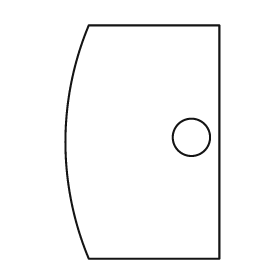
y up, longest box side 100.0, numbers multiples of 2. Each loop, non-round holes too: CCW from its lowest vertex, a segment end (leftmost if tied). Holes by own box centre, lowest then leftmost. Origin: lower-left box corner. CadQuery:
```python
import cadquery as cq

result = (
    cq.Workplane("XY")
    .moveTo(10.0, 0.0)
    .lineTo(66.0, 0.0)
    .lineTo(66.0, 100.0)
    .lineTo(10.0, 100.0)
    .threePointArc((0.0, 50.0), (10.0, 0.0))
    .close()
    .moveTo(54.0, 52.0)
    .circle(8.0)
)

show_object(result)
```